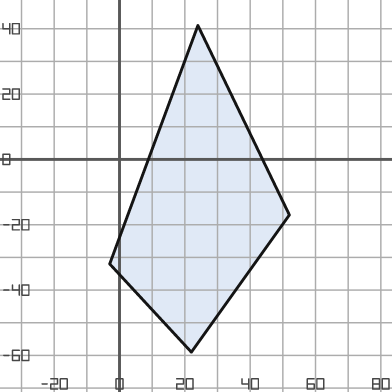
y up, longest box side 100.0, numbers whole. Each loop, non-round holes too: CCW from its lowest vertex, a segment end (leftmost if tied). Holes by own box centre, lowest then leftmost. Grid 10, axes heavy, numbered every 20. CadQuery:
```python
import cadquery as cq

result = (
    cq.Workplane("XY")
    .moveTo(22.0, -59.0)
    .lineTo(52.0, -17.0)
    .lineTo(24.0, 41.0)
    .lineTo(-3.0, -32.0)
    .close()
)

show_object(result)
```